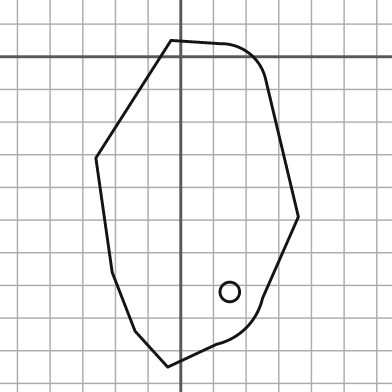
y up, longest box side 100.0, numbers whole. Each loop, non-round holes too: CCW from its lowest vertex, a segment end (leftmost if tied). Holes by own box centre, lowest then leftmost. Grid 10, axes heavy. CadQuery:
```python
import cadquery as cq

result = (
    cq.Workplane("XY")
    .moveTo(-4.0, -95.0)
    .lineTo(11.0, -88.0)
    .threePointArc((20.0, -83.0), (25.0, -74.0))
    .lineTo(36.0, -49.0)
    .lineTo(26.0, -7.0)
    .threePointArc((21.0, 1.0), (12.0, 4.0))
    .lineTo(-3.0, 5.0)
    .lineTo(-26.0, -31.0)
    .lineTo(-21.0, -66.0)
    .lineTo(-14.0, -84.0)
    .close()
    .moveTo(15.0, -72.0)
    .circle(3.0)
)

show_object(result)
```